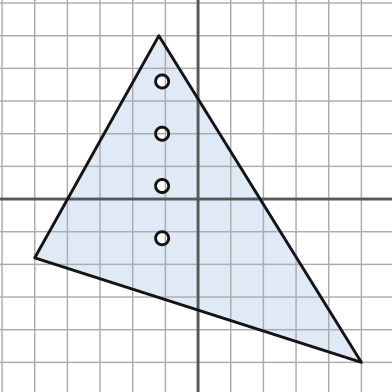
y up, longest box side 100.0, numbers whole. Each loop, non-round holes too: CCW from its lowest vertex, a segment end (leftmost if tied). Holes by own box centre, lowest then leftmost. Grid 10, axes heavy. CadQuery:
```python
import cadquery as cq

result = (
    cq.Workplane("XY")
    .moveTo(50.0, -50.0)
    .lineTo(-12.0, 50.0)
    .lineTo(-50.0, -18.0)
    .close()
    .moveTo(-11.0, -12.0)
    .circle(2.0)
    .moveTo(-11.0, 4.0)
    .circle(2.0)
    .moveTo(-11.0, 20.0)
    .circle(2.0)
    .moveTo(-11.0, 36.0)
    .circle(2.0)
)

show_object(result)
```